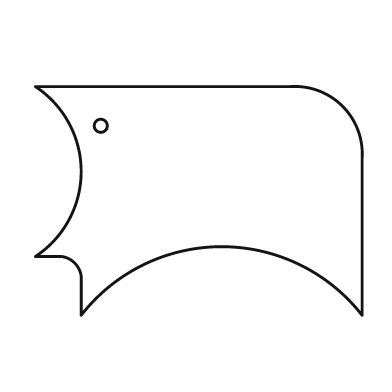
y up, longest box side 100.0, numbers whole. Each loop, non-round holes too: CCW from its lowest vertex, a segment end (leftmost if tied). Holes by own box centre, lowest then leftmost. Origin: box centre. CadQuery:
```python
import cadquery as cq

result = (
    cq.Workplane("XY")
    .moveTo(-36.0, -35.0)
    .threePointArc((7.0, -14.0), (50.0, -35.0))
    .lineTo(50.0, 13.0)
    .threePointArc((44.0, 29.0), (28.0, 35.0))
    .lineTo(-50.0, 35.0)
    .threePointArc((-36.0, 9.0), (-50.0, -17.0))
    .lineTo(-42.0, -17.0)
    .threePointArc((-38.0, -19.0), (-36.0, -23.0))
    .close()
    .moveTo(-30.0, 23.0)
    .circle(2.0)
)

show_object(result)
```